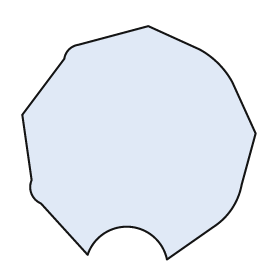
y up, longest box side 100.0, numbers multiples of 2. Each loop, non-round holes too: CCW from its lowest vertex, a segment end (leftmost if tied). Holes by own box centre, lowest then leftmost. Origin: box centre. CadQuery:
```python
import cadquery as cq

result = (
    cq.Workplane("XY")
    .moveTo(12.0, -50.0)
    .lineTo(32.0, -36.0)
    .threePointArc((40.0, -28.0), (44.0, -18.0))
    .lineTo(50.0, 4.0)
    .lineTo(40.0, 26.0)
    .threePointArc((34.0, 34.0), (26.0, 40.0))
    .lineTo(4.0, 50.0)
    .lineTo(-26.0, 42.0)
    .threePointArc((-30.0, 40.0), (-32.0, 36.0))
    .lineTo(-50.0, 12.0)
    .lineTo(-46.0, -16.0)
    .threePointArc((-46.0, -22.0), (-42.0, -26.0))
    .lineTo(-22.0, -48.0)
    .threePointArc((-4.0, -36.0), (12.0, -50.0))
    .close()
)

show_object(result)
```